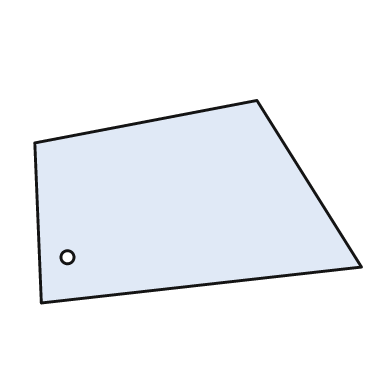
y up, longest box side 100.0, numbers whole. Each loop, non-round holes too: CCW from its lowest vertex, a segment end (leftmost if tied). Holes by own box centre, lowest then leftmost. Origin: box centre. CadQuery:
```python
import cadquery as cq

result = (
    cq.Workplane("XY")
    .moveTo(-48.0, -31.0)
    .lineTo(50.0, -20.0)
    .lineTo(18.0, 31.0)
    .lineTo(-50.0, 18.0)
    .close()
    .moveTo(-40.0, -17.0)
    .circle(2.0)
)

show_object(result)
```